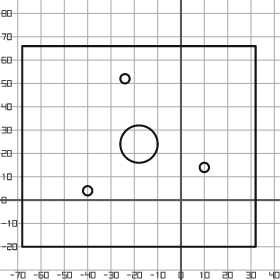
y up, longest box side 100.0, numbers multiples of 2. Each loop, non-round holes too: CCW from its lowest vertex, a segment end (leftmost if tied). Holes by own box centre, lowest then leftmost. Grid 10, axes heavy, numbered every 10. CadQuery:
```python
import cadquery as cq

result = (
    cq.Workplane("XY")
    .moveTo(-68.0, -20.0)
    .lineTo(32.0, -20.0)
    .lineTo(32.0, 66.0)
    .lineTo(-68.0, 66.0)
    .close()
    .moveTo(-40.0, 4.0)
    .circle(2.0)
    .moveTo(10.0, 14.0)
    .circle(2.0)
    .moveTo(-18.0, 24.0)
    .circle(8.0)
    .moveTo(-24.0, 52.0)
    .circle(2.0)
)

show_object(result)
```